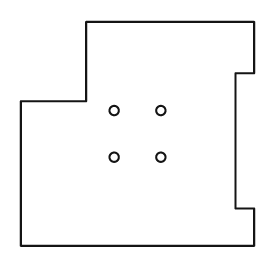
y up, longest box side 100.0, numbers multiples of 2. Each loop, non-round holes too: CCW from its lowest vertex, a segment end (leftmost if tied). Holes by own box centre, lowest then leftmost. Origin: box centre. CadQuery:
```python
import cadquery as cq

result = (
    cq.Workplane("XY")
    .moveTo(-50.0, -48.0)
    .lineTo(50.0, -48.0)
    .lineTo(50.0, -32.0)
    .lineTo(42.0, -32.0)
    .lineTo(42.0, 26.0)
    .lineTo(50.0, 26.0)
    .lineTo(50.0, 48.0)
    .lineTo(-22.0, 48.0)
    .lineTo(-22.0, 14.0)
    .lineTo(-50.0, 14.0)
    .close()
    .moveTo(-10.0, -10.0)
    .circle(2.0)
    .moveTo(10.0, -10.0)
    .circle(2.0)
    .moveTo(-10.0, 10.0)
    .circle(2.0)
    .moveTo(10.0, 10.0)
    .circle(2.0)
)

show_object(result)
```